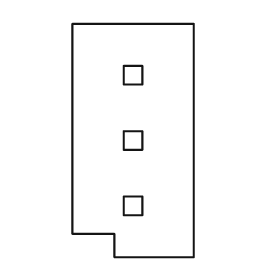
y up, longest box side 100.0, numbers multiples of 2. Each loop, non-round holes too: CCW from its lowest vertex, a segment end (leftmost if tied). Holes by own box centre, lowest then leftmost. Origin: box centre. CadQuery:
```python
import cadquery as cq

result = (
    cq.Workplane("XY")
    .moveTo(-8.0, -50.0)
    .lineTo(26.0, -50.0)
    .lineTo(26.0, 50.0)
    .lineTo(-26.0, 50.0)
    .lineTo(-26.0, -40.0)
    .lineTo(-8.0, -40.0)
    .close()
    .moveTo(-4.0, -32.0)
    .lineTo(4.0, -32.0)
    .lineTo(4.0, -24.0)
    .lineTo(-4.0, -24.0)
    .close()
    .moveTo(-4.0, -4.0)
    .lineTo(4.0, -4.0)
    .lineTo(4.0, 4.0)
    .lineTo(-4.0, 4.0)
    .close()
    .moveTo(-4.0, 24.0)
    .lineTo(4.0, 24.0)
    .lineTo(4.0, 32.0)
    .lineTo(-4.0, 32.0)
    .close()
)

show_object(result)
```